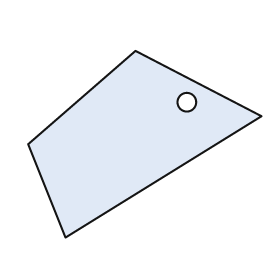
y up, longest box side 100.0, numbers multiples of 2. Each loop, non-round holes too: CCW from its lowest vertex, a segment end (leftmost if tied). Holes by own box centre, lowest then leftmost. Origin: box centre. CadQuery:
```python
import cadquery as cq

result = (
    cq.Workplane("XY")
    .moveTo(-34.0, -40.0)
    .lineTo(50.0, 12.0)
    .lineTo(-4.0, 40.0)
    .lineTo(-50.0, 0.0)
    .close()
    .moveTo(18.0, 18.0)
    .circle(4.0)
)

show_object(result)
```